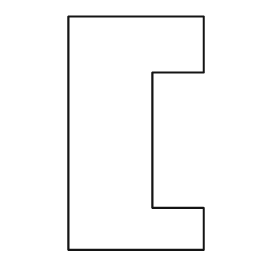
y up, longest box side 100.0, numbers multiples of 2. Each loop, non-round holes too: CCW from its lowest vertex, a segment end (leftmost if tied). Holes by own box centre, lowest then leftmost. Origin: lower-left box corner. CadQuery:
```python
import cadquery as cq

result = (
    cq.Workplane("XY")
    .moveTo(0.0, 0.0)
    .lineTo(58.0, 0.0)
    .lineTo(58.0, 18.0)
    .lineTo(36.0, 18.0)
    .lineTo(36.0, 76.0)
    .lineTo(58.0, 76.0)
    .lineTo(58.0, 100.0)
    .lineTo(0.0, 100.0)
    .close()
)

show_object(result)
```